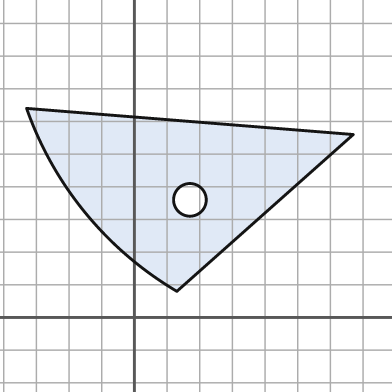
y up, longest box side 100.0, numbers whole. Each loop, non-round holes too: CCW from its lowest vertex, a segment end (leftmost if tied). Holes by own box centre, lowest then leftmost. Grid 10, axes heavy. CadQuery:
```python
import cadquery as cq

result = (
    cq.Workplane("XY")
    .moveTo(13.0, 8.0)
    .lineTo(67.0, 56.0)
    .lineTo(-33.0, 64.0)
    .threePointArc((-15.0, 32.0), (13.0, 8.0))
    .close()
    .moveTo(17.0, 36.0)
    .circle(5.0)
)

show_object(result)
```